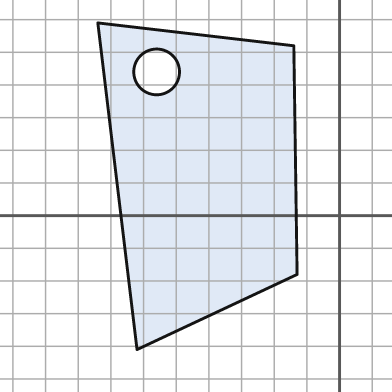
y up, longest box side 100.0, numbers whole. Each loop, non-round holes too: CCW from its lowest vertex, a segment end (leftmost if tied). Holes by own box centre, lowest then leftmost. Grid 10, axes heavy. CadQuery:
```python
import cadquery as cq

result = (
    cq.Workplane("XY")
    .moveTo(-62.0, -41.0)
    .lineTo(-13.0, -18.0)
    .lineTo(-14.0, 52.0)
    .lineTo(-74.0, 59.0)
    .close()
    .moveTo(-56.0, 44.0)
    .circle(7.0)
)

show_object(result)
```